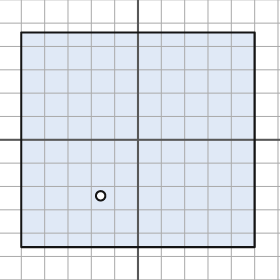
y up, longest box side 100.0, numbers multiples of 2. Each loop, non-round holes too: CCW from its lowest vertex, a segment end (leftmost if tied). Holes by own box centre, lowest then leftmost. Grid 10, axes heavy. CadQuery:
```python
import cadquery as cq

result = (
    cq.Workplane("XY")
    .moveTo(-50.0, -46.0)
    .lineTo(50.0, -46.0)
    .lineTo(50.0, 46.0)
    .lineTo(-50.0, 46.0)
    .close()
    .moveTo(-16.0, -24.0)
    .circle(2.0)
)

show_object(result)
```